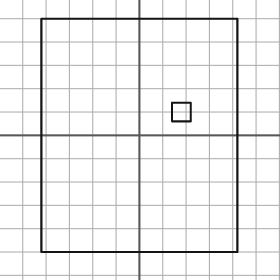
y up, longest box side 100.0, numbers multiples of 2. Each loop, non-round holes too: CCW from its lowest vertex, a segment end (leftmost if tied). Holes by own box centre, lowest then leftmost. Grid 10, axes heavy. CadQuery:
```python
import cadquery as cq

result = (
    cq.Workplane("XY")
    .moveTo(-42.0, -50.0)
    .lineTo(42.0, -50.0)
    .lineTo(42.0, 50.0)
    .lineTo(-42.0, 50.0)
    .close()
    .moveTo(14.0, 6.0)
    .lineTo(22.0, 6.0)
    .lineTo(22.0, 14.0)
    .lineTo(14.0, 14.0)
    .close()
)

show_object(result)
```